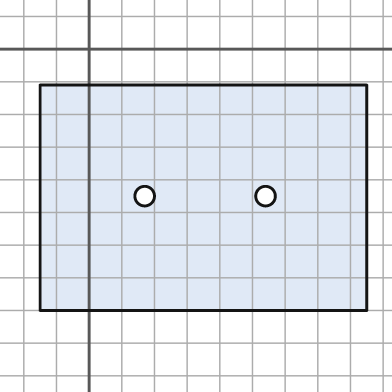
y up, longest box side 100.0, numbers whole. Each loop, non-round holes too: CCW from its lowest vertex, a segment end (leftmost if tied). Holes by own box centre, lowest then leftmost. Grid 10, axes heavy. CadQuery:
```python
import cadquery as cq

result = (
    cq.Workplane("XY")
    .moveTo(-15.0, -80.0)
    .lineTo(85.0, -80.0)
    .lineTo(85.0, -11.0)
    .lineTo(-15.0, -11.0)
    .close()
    .moveTo(17.0, -45.0)
    .circle(3.0)
    .moveTo(54.0, -45.0)
    .circle(3.0)
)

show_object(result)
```